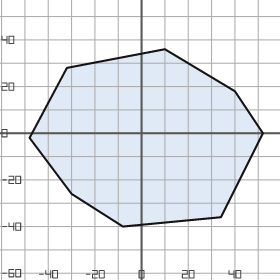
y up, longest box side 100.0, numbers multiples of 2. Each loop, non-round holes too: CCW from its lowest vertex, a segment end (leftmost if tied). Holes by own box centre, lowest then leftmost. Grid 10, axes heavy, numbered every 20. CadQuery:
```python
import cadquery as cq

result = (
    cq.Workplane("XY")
    .moveTo(-8.0, -40.0)
    .lineTo(34.0, -36.0)
    .lineTo(52.0, 0.0)
    .lineTo(40.0, 18.0)
    .lineTo(10.0, 36.0)
    .lineTo(-32.0, 28.0)
    .lineTo(-48.0, -2.0)
    .lineTo(-30.0, -26.0)
    .close()
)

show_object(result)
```